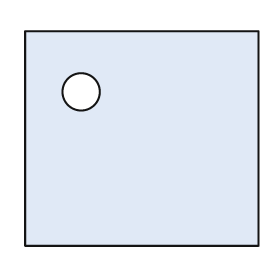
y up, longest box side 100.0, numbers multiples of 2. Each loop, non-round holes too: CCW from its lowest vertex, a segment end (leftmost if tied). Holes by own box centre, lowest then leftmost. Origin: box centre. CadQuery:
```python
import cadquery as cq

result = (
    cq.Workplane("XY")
    .moveTo(-50.0, -46.0)
    .lineTo(50.0, -46.0)
    .lineTo(50.0, 46.0)
    .lineTo(-50.0, 46.0)
    .close()
    .moveTo(-26.0, 20.0)
    .circle(8.0)
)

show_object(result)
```